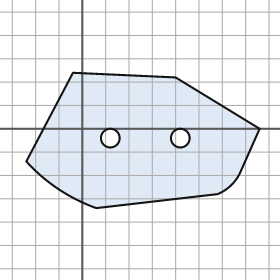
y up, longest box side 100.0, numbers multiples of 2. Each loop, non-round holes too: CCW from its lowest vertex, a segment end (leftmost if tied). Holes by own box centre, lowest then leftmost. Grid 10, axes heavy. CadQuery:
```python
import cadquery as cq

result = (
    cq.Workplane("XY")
    .moveTo(6.0, -34.0)
    .lineTo(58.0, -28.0)
    .threePointArc((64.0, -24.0), (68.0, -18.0))
    .lineTo(76.0, 0.0)
    .lineTo(40.0, 22.0)
    .lineTo(-4.0, 24.0)
    .lineTo(-24.0, -14.0)
    .threePointArc((-10.0, -26.0), (6.0, -34.0))
    .close()
    .moveTo(12.0, -4.0)
    .circle(4.0)
    .moveTo(42.0, -4.0)
    .circle(4.0)
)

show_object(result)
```